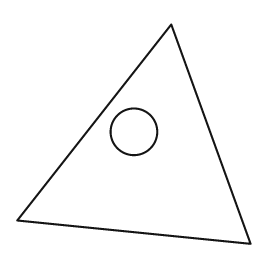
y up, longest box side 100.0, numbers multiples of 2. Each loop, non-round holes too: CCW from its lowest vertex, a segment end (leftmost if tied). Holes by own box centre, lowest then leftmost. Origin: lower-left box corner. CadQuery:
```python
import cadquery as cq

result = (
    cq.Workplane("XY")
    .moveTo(100.0, 0.0)
    .lineTo(66.0, 94.0)
    .lineTo(0.0, 10.0)
    .close()
    .moveTo(50.0, 48.0)
    .circle(10.0)
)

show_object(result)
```